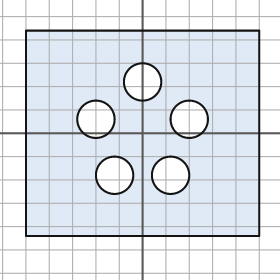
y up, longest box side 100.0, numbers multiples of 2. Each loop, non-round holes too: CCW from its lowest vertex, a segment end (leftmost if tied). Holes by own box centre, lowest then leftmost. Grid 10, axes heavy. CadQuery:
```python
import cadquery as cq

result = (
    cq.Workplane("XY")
    .moveTo(-50.0, -44.0)
    .lineTo(50.0, -44.0)
    .lineTo(50.0, 44.0)
    .lineTo(-50.0, 44.0)
    .close()
    .moveTo(-12.0, -18.0)
    .circle(8.0)
    .moveTo(12.0, -18.0)
    .circle(8.0)
    .moveTo(-20.0, 6.0)
    .circle(8.0)
    .moveTo(20.0, 6.0)
    .circle(8.0)
    .moveTo(0.0, 22.0)
    .circle(8.0)
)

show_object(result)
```